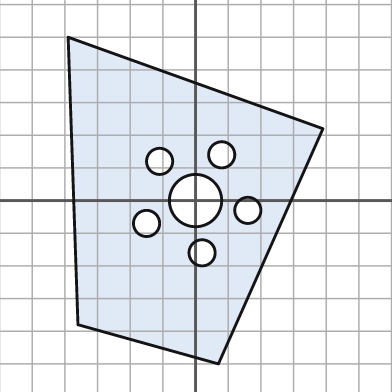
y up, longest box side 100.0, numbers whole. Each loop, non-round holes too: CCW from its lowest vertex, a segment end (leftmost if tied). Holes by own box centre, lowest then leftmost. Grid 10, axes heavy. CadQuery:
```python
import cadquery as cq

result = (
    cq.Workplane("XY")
    .moveTo(7.0, -50.0)
    .lineTo(39.0, 22.0)
    .lineTo(-39.0, 50.0)
    .lineTo(-36.0, -38.0)
    .close()
    .moveTo(2.0, -16.0)
    .circle(4.0)
    .moveTo(-15.0, -7.0)
    .circle(4.0)
    .moveTo(16.0, -3.0)
    .circle(4.0)
    .moveTo(0.0, 0.0)
    .circle(8.0)
    .moveTo(-11.0, 12.0)
    .circle(4.0)
    .moveTo(8.0, 14.0)
    .circle(4.0)
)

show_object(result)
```